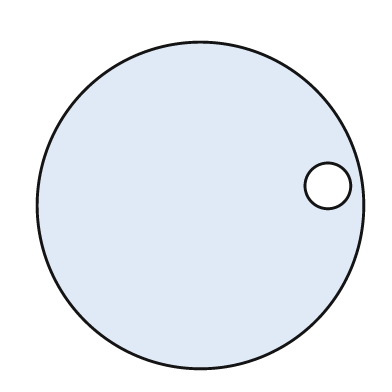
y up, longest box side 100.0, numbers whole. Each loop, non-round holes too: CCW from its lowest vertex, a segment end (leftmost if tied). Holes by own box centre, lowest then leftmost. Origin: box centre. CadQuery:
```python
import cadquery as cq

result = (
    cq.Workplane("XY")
    .moveTo(0.0, 0.0)
    .circle(50.0)
    .moveTo(39.0, 6.0)
    .circle(7.0)
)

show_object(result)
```